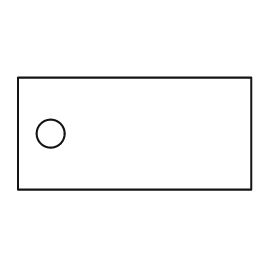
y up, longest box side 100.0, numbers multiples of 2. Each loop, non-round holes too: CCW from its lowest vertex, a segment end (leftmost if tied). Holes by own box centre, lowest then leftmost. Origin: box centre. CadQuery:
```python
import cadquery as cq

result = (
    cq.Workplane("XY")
    .moveTo(-50.0, -24.0)
    .lineTo(50.0, -24.0)
    .lineTo(50.0, 24.0)
    .lineTo(-50.0, 24.0)
    .close()
    .moveTo(-36.0, 0.0)
    .circle(6.0)
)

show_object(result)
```